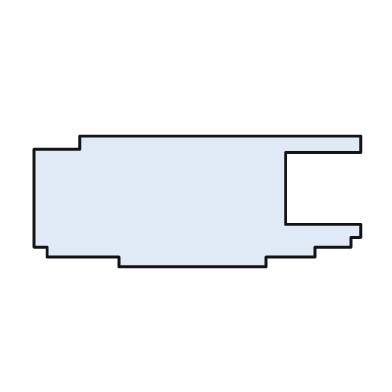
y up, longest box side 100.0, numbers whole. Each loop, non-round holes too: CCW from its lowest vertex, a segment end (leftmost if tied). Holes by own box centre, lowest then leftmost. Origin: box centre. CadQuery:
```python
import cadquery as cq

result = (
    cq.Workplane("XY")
    .moveTo(-24.0, -20.0)
    .lineTo(21.0, -20.0)
    .lineTo(21.0, -17.0)
    .lineTo(36.0, -17.0)
    .lineTo(36.0, -14.0)
    .lineTo(47.0, -14.0)
    .lineTo(47.0, -11.0)
    .lineTo(50.0, -11.0)
    .lineTo(50.0, -7.0)
    .lineTo(27.0, -7.0)
    .lineTo(27.0, 15.0)
    .lineTo(50.0, 15.0)
    .lineTo(50.0, 20.0)
    .lineTo(-36.0, 20.0)
    .lineTo(-36.0, 16.0)
    .lineTo(-50.0, 16.0)
    .lineTo(-50.0, -14.0)
    .lineTo(-46.0, -14.0)
    .lineTo(-46.0, -17.0)
    .lineTo(-24.0, -17.0)
    .close()
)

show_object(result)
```